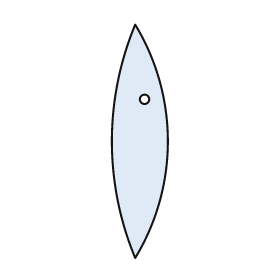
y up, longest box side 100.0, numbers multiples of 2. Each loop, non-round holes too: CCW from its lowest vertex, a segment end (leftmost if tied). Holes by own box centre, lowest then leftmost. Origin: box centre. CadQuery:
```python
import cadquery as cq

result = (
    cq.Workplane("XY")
    .moveTo(-2.0, -50.0)
    .threePointArc((12.0, 0.0), (-2.0, 50.0))
    .threePointArc((-12.0, 0.0), (-2.0, -50.0))
    .close()
    .moveTo(2.0, 18.0)
    .circle(2.0)
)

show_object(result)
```